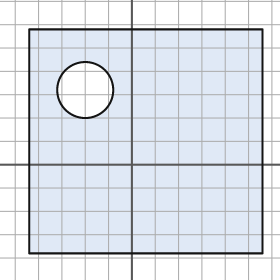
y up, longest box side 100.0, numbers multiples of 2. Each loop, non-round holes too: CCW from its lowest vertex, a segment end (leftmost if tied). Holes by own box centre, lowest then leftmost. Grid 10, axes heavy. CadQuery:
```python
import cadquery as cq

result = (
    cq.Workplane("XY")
    .moveTo(-44.0, -38.0)
    .lineTo(56.0, -38.0)
    .lineTo(56.0, 58.0)
    .lineTo(-44.0, 58.0)
    .close()
    .moveTo(-20.0, 32.0)
    .circle(12.0)
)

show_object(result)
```